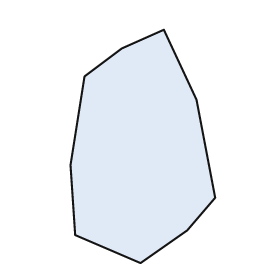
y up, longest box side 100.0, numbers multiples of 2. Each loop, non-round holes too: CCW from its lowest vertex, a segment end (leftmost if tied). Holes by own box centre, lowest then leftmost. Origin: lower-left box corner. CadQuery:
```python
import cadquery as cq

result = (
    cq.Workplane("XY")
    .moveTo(30.0, 0.0)
    .lineTo(50.0, 14.0)
    .lineTo(62.0, 28.0)
    .lineTo(54.0, 70.0)
    .lineTo(40.0, 100.0)
    .lineTo(22.0, 92.0)
    .lineTo(6.0, 80.0)
    .lineTo(0.0, 42.0)
    .lineTo(2.0, 12.0)
    .close()
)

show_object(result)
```